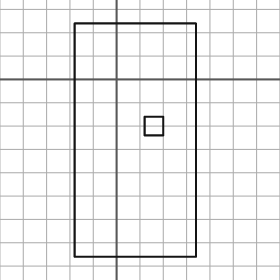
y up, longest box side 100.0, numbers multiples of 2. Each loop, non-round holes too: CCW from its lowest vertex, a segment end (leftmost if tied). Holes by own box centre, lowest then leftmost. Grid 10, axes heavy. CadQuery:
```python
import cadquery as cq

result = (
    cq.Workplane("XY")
    .moveTo(-18.0, -76.0)
    .lineTo(34.0, -76.0)
    .lineTo(34.0, 24.0)
    .lineTo(-18.0, 24.0)
    .close()
    .moveTo(12.0, -24.0)
    .lineTo(20.0, -24.0)
    .lineTo(20.0, -16.0)
    .lineTo(12.0, -16.0)
    .close()
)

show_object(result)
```